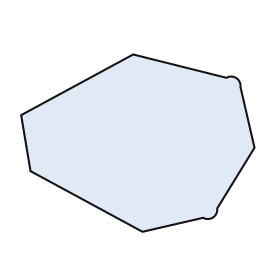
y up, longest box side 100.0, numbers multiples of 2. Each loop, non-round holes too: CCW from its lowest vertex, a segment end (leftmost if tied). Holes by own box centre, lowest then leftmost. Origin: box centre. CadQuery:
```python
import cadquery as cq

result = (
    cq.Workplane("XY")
    .moveTo(2.0, -38.0)
    .lineTo(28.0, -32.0)
    .threePointArc((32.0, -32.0), (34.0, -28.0))
    .lineTo(50.0, -2.0)
    .lineTo(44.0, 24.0)
    .threePointArc((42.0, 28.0), (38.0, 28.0))
    .lineTo(-2.0, 38.0)
    .lineTo(-50.0, 12.0)
    .lineTo(-46.0, -12.0)
    .close()
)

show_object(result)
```